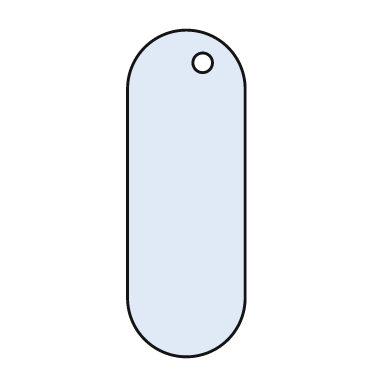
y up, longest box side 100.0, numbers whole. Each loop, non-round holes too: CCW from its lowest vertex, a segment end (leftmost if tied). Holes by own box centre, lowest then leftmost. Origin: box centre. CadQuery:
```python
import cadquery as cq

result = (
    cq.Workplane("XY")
    .moveTo(-18.0, -32.0)
    .threePointArc((0.0, -50.0), (18.0, -32.0))
    .lineTo(18.0, 32.0)
    .threePointArc((0.0, 50.0), (-18.0, 32.0))
    .close()
    .moveTo(5.0, 40.0)
    .circle(3.0)
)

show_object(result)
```